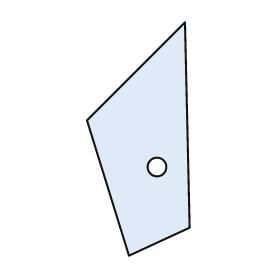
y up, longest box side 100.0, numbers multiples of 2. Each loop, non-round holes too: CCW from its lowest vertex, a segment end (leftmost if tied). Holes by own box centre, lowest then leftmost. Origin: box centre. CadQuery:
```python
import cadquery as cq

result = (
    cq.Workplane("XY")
    .moveTo(-4.0, -50.0)
    .lineTo(22.0, -38.0)
    .lineTo(20.0, 50.0)
    .lineTo(-22.0, 8.0)
    .close()
    .moveTo(8.0, -12.0)
    .circle(4.0)
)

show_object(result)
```